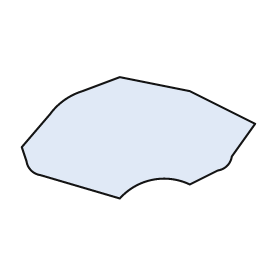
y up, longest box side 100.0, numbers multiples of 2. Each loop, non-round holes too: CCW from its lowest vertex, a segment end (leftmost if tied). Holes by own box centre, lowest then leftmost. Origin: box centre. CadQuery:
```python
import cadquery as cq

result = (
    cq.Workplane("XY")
    .moveTo(-8.0, -26.0)
    .threePointArc((6.0, -18.0), (22.0, -20.0))
    .lineTo(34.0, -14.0)
    .threePointArc((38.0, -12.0), (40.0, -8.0))
    .lineTo(50.0, 6.0)
    .lineTo(22.0, 20.0)
    .lineTo(-8.0, 26.0)
    .lineTo(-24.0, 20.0)
    .threePointArc((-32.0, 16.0), (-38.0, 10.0))
    .lineTo(-50.0, -4.0)
    .lineTo(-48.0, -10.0)
    .threePointArc((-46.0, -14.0), (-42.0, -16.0))
    .close()
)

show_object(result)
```